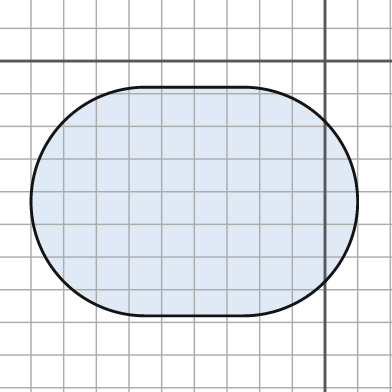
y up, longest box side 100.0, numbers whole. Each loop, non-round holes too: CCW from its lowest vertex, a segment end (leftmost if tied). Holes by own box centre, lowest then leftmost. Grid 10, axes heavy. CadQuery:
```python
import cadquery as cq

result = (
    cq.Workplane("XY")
    .moveTo(-55.0, -78.0)
    .lineTo(-25.0, -78.0)
    .threePointArc((10.0, -43.0), (-25.0, -8.0))
    .lineTo(-55.0, -8.0)
    .threePointArc((-90.0, -43.0), (-55.0, -78.0))
    .close()
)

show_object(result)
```